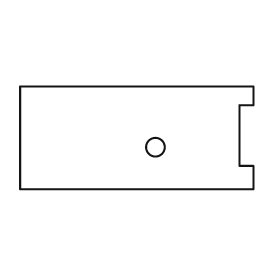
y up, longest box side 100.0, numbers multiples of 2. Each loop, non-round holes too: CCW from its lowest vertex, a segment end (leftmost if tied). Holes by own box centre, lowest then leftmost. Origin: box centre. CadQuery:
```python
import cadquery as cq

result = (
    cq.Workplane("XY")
    .moveTo(-50.0, -22.0)
    .lineTo(50.0, -22.0)
    .lineTo(50.0, -12.0)
    .lineTo(44.0, -12.0)
    .lineTo(44.0, 14.0)
    .lineTo(50.0, 14.0)
    .lineTo(50.0, 22.0)
    .lineTo(-50.0, 22.0)
    .close()
    .moveTo(8.0, -4.0)
    .circle(4.0)
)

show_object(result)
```